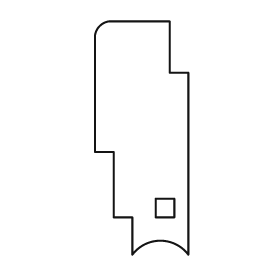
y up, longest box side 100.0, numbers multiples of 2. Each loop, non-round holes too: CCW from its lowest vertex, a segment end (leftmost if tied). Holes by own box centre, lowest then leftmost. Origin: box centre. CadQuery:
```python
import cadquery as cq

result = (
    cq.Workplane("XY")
    .moveTo(-4.0, -50.0)
    .threePointArc((8.0, -44.0), (20.0, -50.0))
    .lineTo(20.0, 28.0)
    .lineTo(12.0, 28.0)
    .lineTo(12.0, 50.0)
    .lineTo(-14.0, 50.0)
    .threePointArc((-18.0, 48.0), (-20.0, 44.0))
    .lineTo(-20.0, -6.0)
    .lineTo(-12.0, -6.0)
    .lineTo(-12.0, -34.0)
    .lineTo(-4.0, -34.0)
    .close()
    .moveTo(6.0, -34.0)
    .lineTo(14.0, -34.0)
    .lineTo(14.0, -26.0)
    .lineTo(6.0, -26.0)
    .close()
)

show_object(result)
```